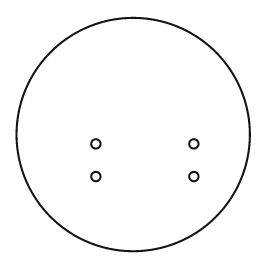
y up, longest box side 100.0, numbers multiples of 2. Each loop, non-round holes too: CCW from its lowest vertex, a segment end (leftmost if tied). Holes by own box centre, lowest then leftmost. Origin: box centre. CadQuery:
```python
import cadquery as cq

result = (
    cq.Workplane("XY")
    .moveTo(0.0, 0.0)
    .circle(50.0)
    .moveTo(-16.0, -18.0)
    .circle(2.0)
    .moveTo(26.0, -18.0)
    .circle(2.0)
    .moveTo(-16.0, -4.0)
    .circle(2.0)
    .moveTo(26.0, -4.0)
    .circle(2.0)
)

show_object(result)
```